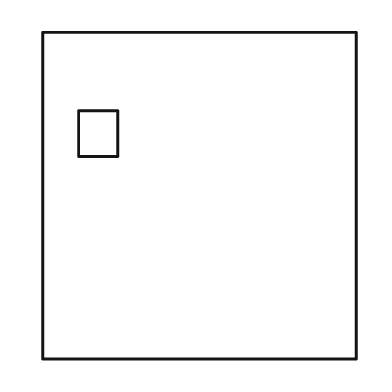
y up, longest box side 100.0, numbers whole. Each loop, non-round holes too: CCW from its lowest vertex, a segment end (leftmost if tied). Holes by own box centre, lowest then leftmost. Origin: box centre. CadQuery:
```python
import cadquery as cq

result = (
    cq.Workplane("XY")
    .moveTo(-48.0, -50.0)
    .lineTo(48.0, -50.0)
    .lineTo(48.0, 50.0)
    .lineTo(-48.0, 50.0)
    .close()
    .moveTo(-37.0, 12.0)
    .lineTo(-25.0, 12.0)
    .lineTo(-25.0, 26.0)
    .lineTo(-37.0, 26.0)
    .close()
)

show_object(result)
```